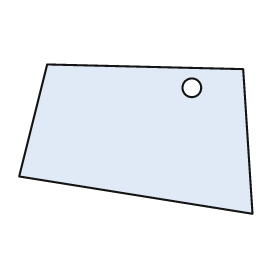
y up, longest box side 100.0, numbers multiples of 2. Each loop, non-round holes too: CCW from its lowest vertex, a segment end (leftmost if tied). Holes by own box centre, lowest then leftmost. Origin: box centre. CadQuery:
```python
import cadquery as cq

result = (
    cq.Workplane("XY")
    .moveTo(50.0, -32.0)
    .lineTo(46.0, 30.0)
    .lineTo(-38.0, 32.0)
    .lineTo(-50.0, -16.0)
    .close()
    .moveTo(24.0, 22.0)
    .circle(4.0)
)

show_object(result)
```